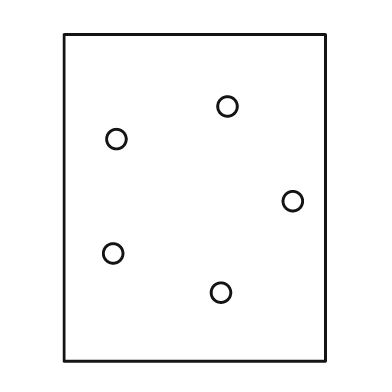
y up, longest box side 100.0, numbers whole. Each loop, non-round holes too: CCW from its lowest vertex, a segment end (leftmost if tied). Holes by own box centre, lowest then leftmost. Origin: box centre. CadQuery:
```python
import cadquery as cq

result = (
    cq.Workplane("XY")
    .moveTo(-40.0, -50.0)
    .lineTo(40.0, -50.0)
    .lineTo(40.0, 50.0)
    .lineTo(-40.0, 50.0)
    .close()
    .moveTo(8.0, -29.0)
    .circle(3.0)
    .moveTo(-25.0, -17.0)
    .circle(3.0)
    .moveTo(30.0, -1.0)
    .circle(3.0)
    .moveTo(-24.0, 18.0)
    .circle(3.0)
    .moveTo(10.0, 28.0)
    .circle(3.0)
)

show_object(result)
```